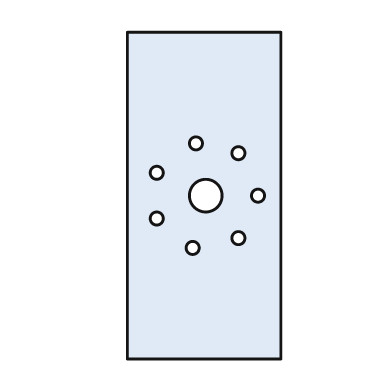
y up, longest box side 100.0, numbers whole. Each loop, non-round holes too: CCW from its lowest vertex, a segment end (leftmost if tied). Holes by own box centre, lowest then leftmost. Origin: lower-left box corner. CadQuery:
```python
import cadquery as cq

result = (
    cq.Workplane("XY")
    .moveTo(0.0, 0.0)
    .lineTo(47.0, 0.0)
    .lineTo(47.0, 100.0)
    .lineTo(0.0, 100.0)
    .close()
    .moveTo(20.0, 34.0)
    .circle(2.0)
    .moveTo(34.0, 37.0)
    .circle(2.0)
    .moveTo(9.0, 43.0)
    .circle(2.0)
    .moveTo(24.0, 50.0)
    .circle(5.0)
    .moveTo(40.0, 50.0)
    .circle(2.0)
    .moveTo(9.0, 57.0)
    .circle(2.0)
    .moveTo(34.0, 63.0)
    .circle(2.0)
    .moveTo(21.0, 66.0)
    .circle(2.0)
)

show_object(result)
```